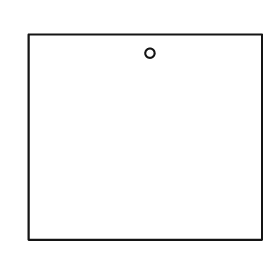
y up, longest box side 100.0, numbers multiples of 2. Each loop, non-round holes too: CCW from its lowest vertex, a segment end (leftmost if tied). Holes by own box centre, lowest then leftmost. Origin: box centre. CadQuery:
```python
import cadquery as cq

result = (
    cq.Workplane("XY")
    .moveTo(-50.0, -44.0)
    .lineTo(50.0, -44.0)
    .lineTo(50.0, 44.0)
    .lineTo(-50.0, 44.0)
    .close()
    .moveTo(2.0, 36.0)
    .circle(2.0)
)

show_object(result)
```